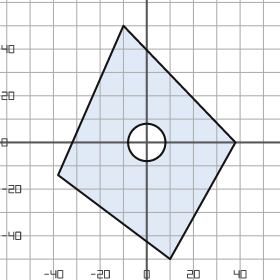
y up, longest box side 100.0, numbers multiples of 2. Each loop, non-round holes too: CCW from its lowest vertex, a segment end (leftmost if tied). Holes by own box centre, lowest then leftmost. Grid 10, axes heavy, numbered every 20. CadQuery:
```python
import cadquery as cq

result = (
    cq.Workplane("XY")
    .moveTo(10.0, -50.0)
    .lineTo(38.0, 0.0)
    .lineTo(-10.0, 50.0)
    .lineTo(-38.0, -14.0)
    .close()
    .moveTo(0.0, 0.0)
    .circle(8.0)
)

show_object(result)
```